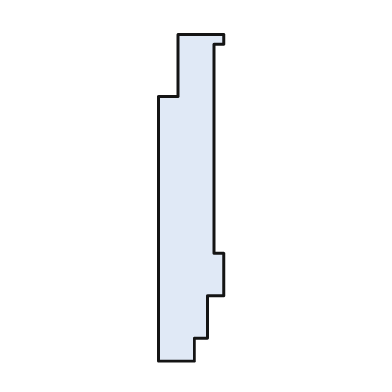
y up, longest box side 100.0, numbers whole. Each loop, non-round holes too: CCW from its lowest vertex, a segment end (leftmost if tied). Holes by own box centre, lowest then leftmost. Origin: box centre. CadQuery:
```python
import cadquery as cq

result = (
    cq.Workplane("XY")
    .moveTo(-10.0, -50.0)
    .lineTo(1.0, -50.0)
    .lineTo(1.0, -43.0)
    .lineTo(5.0, -43.0)
    .lineTo(5.0, -30.0)
    .lineTo(10.0, -30.0)
    .lineTo(10.0, -17.0)
    .lineTo(7.0, -17.0)
    .lineTo(7.0, 47.0)
    .lineTo(10.0, 47.0)
    .lineTo(10.0, 50.0)
    .lineTo(-4.0, 50.0)
    .lineTo(-4.0, 31.0)
    .lineTo(-10.0, 31.0)
    .close()
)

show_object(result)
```